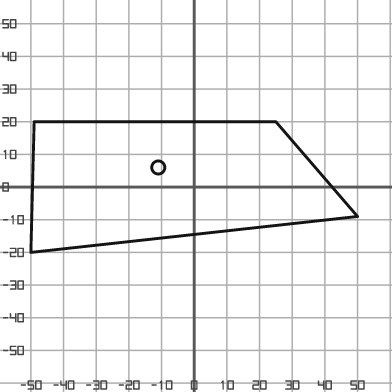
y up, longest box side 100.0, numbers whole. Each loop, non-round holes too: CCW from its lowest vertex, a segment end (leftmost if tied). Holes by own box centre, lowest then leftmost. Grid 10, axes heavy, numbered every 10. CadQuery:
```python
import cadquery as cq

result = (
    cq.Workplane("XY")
    .moveTo(-50.0, -20.0)
    .lineTo(50.0, -9.0)
    .lineTo(25.0, 20.0)
    .lineTo(-49.0, 20.0)
    .close()
    .moveTo(-11.0, 6.0)
    .circle(2.0)
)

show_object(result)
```